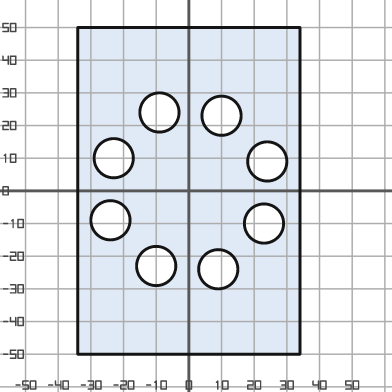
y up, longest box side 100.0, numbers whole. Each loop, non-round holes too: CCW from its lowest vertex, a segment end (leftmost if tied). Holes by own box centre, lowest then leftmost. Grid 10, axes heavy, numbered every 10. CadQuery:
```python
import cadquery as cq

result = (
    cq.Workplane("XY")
    .moveTo(-34.0, -50.0)
    .lineTo(34.0, -50.0)
    .lineTo(34.0, 50.0)
    .lineTo(-34.0, 50.0)
    .close()
    .moveTo(9.0, -24.0)
    .circle(6.0)
    .moveTo(-10.0, -23.0)
    .circle(6.0)
    .moveTo(23.0, -10.0)
    .circle(6.0)
    .moveTo(-24.0, -9.0)
    .circle(6.0)
    .moveTo(24.0, 9.0)
    .circle(6.0)
    .moveTo(-23.0, 10.0)
    .circle(6.0)
    .moveTo(10.0, 23.0)
    .circle(6.0)
    .moveTo(-9.0, 24.0)
    .circle(6.0)
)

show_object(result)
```